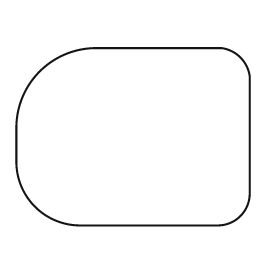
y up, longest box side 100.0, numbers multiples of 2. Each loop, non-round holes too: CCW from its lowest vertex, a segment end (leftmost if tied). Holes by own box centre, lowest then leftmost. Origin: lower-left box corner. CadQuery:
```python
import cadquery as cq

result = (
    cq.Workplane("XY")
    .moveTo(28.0, 0.0)
    .lineTo(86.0, 0.0)
    .threePointArc((96.0, 4.0), (100.0, 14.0))
    .lineTo(100.0, 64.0)
    .threePointArc((96.0, 72.0), (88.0, 76.0))
    .lineTo(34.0, 76.0)
    .threePointArc((10.0, 66.0), (0.0, 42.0))
    .lineTo(0.0, 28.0)
    .threePointArc((8.0, 8.0), (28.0, 0.0))
    .close()
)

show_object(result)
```